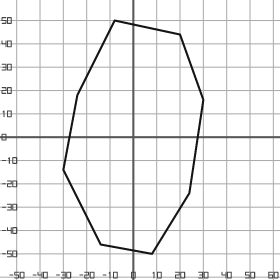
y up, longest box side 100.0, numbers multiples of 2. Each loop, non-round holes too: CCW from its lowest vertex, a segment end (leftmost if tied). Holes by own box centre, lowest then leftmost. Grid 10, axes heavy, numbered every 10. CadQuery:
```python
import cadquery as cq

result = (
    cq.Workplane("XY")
    .moveTo(8.0, -50.0)
    .lineTo(24.0, -24.0)
    .lineTo(30.0, 16.0)
    .lineTo(20.0, 44.0)
    .lineTo(-8.0, 50.0)
    .lineTo(-24.0, 18.0)
    .lineTo(-30.0, -14.0)
    .lineTo(-14.0, -46.0)
    .close()
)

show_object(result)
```